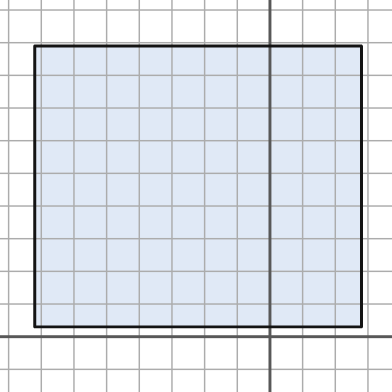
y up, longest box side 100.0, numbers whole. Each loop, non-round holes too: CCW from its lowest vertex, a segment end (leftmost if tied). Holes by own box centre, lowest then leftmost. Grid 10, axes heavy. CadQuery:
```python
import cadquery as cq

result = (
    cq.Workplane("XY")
    .moveTo(-72.0, 3.0)
    .lineTo(28.0, 3.0)
    .lineTo(28.0, 89.0)
    .lineTo(-72.0, 89.0)
    .close()
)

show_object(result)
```